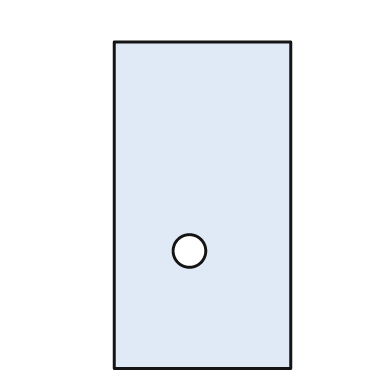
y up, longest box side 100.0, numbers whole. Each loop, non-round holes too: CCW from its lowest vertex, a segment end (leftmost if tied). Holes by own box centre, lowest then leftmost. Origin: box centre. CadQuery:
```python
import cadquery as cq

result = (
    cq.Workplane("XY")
    .moveTo(-27.0, -50.0)
    .lineTo(27.0, -50.0)
    .lineTo(27.0, 50.0)
    .lineTo(-27.0, 50.0)
    .close()
    .moveTo(-4.0, -14.0)
    .circle(5.0)
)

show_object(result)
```